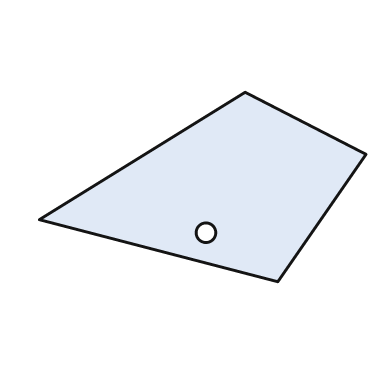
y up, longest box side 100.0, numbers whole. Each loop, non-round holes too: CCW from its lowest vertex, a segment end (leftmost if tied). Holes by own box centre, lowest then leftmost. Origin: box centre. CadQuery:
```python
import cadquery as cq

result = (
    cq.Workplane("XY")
    .moveTo(23.0, -29.0)
    .lineTo(50.0, 10.0)
    .lineTo(13.0, 29.0)
    .lineTo(-50.0, -10.0)
    .close()
    .moveTo(1.0, -14.0)
    .circle(3.0)
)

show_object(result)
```